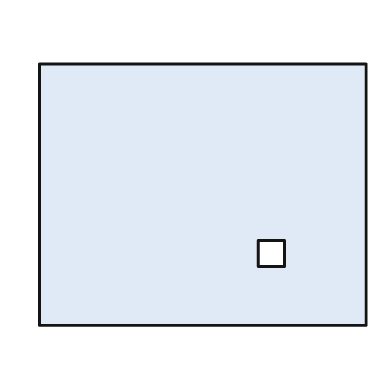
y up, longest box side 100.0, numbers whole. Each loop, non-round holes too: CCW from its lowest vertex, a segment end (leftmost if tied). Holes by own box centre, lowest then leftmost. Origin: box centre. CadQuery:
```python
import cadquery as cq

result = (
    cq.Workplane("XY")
    .moveTo(-50.0, -40.0)
    .lineTo(50.0, -40.0)
    .lineTo(50.0, 40.0)
    .lineTo(-50.0, 40.0)
    .close()
    .moveTo(17.0, -22.0)
    .lineTo(25.0, -22.0)
    .lineTo(25.0, -14.0)
    .lineTo(17.0, -14.0)
    .close()
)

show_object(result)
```